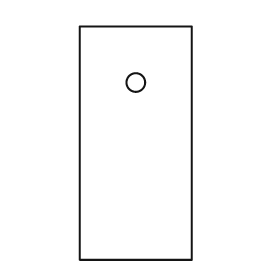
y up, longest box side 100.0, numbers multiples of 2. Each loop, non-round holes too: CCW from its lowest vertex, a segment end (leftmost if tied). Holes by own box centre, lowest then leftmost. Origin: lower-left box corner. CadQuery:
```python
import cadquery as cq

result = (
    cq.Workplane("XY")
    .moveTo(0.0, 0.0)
    .lineTo(48.0, 0.0)
    .lineTo(48.0, 100.0)
    .lineTo(0.0, 100.0)
    .close()
    .moveTo(24.0, 76.0)
    .circle(4.0)
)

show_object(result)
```